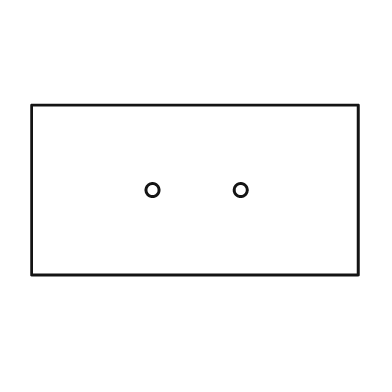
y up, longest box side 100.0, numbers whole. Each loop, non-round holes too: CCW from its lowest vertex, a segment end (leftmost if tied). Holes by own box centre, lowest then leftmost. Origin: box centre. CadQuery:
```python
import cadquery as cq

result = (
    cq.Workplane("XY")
    .moveTo(-50.0, -26.0)
    .lineTo(50.0, -26.0)
    .lineTo(50.0, 26.0)
    .lineTo(-50.0, 26.0)
    .close()
    .moveTo(-13.0, 0.0)
    .circle(2.0)
    .moveTo(14.0, 0.0)
    .circle(2.0)
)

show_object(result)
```